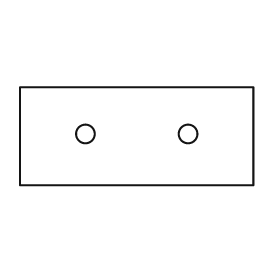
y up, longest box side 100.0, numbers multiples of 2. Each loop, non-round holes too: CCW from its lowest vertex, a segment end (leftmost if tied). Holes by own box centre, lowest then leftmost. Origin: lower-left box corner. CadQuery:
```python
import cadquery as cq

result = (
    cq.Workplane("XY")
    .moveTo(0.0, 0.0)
    .lineTo(100.0, 0.0)
    .lineTo(100.0, 42.0)
    .lineTo(0.0, 42.0)
    .close()
    .moveTo(28.0, 22.0)
    .circle(4.0)
    .moveTo(72.0, 22.0)
    .circle(4.0)
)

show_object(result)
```